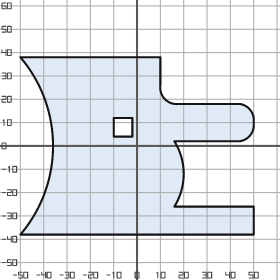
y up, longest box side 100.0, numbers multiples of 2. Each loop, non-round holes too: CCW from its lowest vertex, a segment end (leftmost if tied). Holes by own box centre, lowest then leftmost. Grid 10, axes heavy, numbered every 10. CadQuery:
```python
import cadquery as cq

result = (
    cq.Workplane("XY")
    .moveTo(-50.0, -38.0)
    .lineTo(50.0, -38.0)
    .lineTo(50.0, -26.0)
    .lineTo(16.0, -26.0)
    .threePointArc((20.0, -12.0), (16.0, 2.0))
    .lineTo(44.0, 2.0)
    .threePointArc((48.0, 4.0), (50.0, 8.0))
    .lineTo(50.0, 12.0)
    .threePointArc((48.0, 16.0), (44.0, 18.0))
    .lineTo(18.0, 18.0)
    .threePointArc((12.0, 20.0), (10.0, 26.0))
    .lineTo(10.0, 38.0)
    .lineTo(-50.0, 38.0)
    .threePointArc((-36.0, 0.0), (-50.0, -38.0))
    .close()
    .moveTo(-10.0, 4.0)
    .lineTo(-2.0, 4.0)
    .lineTo(-2.0, 12.0)
    .lineTo(-10.0, 12.0)
    .close()
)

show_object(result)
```